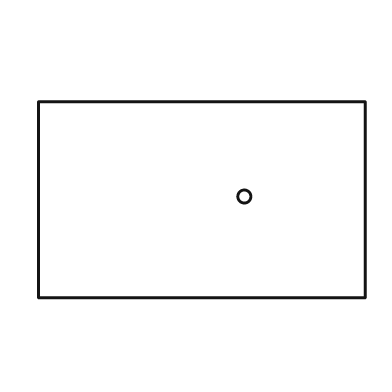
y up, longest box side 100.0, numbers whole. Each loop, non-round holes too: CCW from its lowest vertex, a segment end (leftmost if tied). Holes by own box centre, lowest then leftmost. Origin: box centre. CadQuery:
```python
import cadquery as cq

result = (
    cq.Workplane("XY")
    .moveTo(-50.0, -30.0)
    .lineTo(50.0, -30.0)
    .lineTo(50.0, 30.0)
    .lineTo(-50.0, 30.0)
    .close()
    .moveTo(13.0, 1.0)
    .circle(2.0)
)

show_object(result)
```